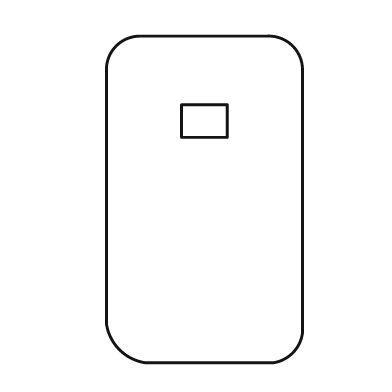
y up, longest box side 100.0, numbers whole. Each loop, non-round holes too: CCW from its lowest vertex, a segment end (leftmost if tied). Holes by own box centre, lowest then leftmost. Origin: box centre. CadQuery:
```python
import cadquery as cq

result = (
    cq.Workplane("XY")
    .moveTo(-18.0, -50.0)
    .lineTo(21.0, -50.0)
    .threePointArc((27.0, -47.0), (30.0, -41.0))
    .lineTo(30.0, 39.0)
    .threePointArc((27.0, 47.0), (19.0, 50.0))
    .lineTo(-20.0, 50.0)
    .threePointArc((-27.0, 47.0), (-30.0, 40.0))
    .lineTo(-30.0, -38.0)
    .threePointArc((-26.0, -46.0), (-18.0, -50.0))
    .close()
    .moveTo(-7.0, 19.0)
    .lineTo(7.0, 19.0)
    .lineTo(7.0, 29.0)
    .lineTo(-7.0, 29.0)
    .close()
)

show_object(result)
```